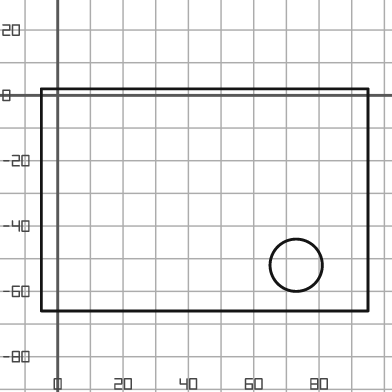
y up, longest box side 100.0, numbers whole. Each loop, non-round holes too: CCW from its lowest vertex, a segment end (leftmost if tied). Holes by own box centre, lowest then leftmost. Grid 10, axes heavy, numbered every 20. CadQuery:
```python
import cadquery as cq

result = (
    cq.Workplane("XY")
    .moveTo(-5.0, -66.0)
    .lineTo(95.0, -66.0)
    .lineTo(95.0, 2.0)
    .lineTo(-5.0, 2.0)
    .close()
    .moveTo(73.0, -52.0)
    .circle(8.0)
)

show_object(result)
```